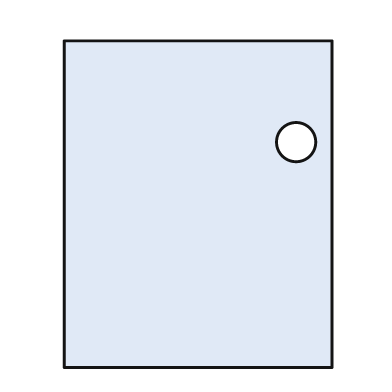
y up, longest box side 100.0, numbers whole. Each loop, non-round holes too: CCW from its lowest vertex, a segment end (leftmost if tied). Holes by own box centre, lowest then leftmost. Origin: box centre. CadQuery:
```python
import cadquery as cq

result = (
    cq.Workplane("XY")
    .moveTo(-41.0, -50.0)
    .lineTo(41.0, -50.0)
    .lineTo(41.0, 50.0)
    .lineTo(-41.0, 50.0)
    .close()
    .moveTo(30.0, 19.0)
    .circle(6.0)
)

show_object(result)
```